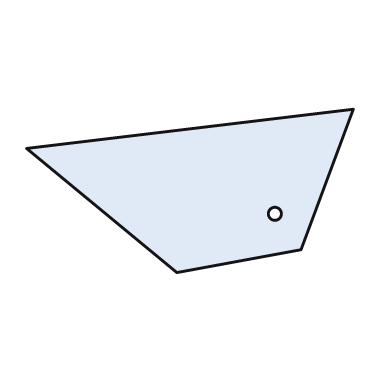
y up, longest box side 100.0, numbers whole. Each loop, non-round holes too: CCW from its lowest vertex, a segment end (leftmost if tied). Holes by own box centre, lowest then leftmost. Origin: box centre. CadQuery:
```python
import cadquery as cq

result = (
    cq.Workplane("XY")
    .moveTo(-4.0, -25.0)
    .lineTo(34.0, -18.0)
    .lineTo(50.0, 25.0)
    .lineTo(-50.0, 13.0)
    .close()
    .moveTo(26.0, -7.0)
    .circle(2.0)
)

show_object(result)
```